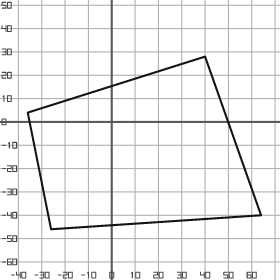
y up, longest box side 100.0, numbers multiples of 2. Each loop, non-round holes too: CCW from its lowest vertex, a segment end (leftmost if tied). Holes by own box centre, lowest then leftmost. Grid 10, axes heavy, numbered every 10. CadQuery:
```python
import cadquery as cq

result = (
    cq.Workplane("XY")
    .moveTo(-26.0, -46.0)
    .lineTo(64.0, -40.0)
    .lineTo(40.0, 28.0)
    .lineTo(-36.0, 4.0)
    .close()
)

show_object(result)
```